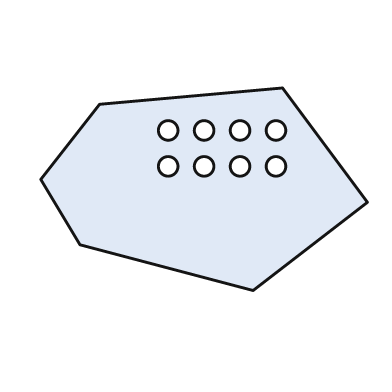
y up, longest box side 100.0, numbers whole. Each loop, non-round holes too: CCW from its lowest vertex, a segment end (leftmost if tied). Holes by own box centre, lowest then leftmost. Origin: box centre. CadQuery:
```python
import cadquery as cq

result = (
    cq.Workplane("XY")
    .moveTo(15.0, -31.0)
    .lineTo(50.0, -4.0)
    .lineTo(24.0, 31.0)
    .lineTo(-32.0, 26.0)
    .lineTo(-50.0, 3.0)
    .lineTo(-38.0, -17.0)
    .close()
    .moveTo(-11.0, 7.0)
    .circle(3.0)
    .moveTo(0.0, 7.0)
    .circle(3.0)
    .moveTo(11.0, 7.0)
    .circle(3.0)
    .moveTo(22.0, 7.0)
    .circle(3.0)
    .moveTo(-11.0, 18.0)
    .circle(3.0)
    .moveTo(0.0, 18.0)
    .circle(3.0)
    .moveTo(11.0, 18.0)
    .circle(3.0)
    .moveTo(22.0, 18.0)
    .circle(3.0)
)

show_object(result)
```